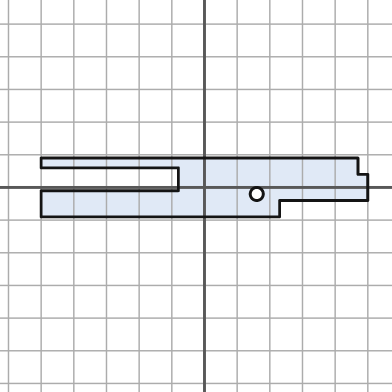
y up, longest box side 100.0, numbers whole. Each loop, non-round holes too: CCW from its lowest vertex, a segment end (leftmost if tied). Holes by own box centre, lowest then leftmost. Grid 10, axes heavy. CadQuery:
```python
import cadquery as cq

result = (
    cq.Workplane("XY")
    .moveTo(-50.0, -9.0)
    .lineTo(23.0, -9.0)
    .lineTo(23.0, -4.0)
    .lineTo(50.0, -4.0)
    .lineTo(50.0, 4.0)
    .lineTo(47.0, 4.0)
    .lineTo(47.0, 9.0)
    .lineTo(-50.0, 9.0)
    .lineTo(-50.0, 6.0)
    .lineTo(-8.0, 6.0)
    .lineTo(-8.0, -1.0)
    .lineTo(-50.0, -1.0)
    .close()
    .moveTo(16.0, -2.0)
    .circle(2.0)
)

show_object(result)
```